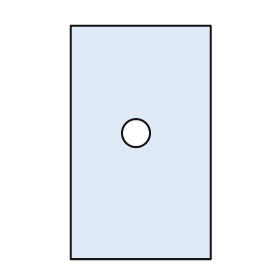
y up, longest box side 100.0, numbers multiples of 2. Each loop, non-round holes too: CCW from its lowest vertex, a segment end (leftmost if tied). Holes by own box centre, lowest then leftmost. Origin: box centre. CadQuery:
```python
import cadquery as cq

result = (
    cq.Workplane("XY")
    .moveTo(-30.0, -50.0)
    .lineTo(30.0, -50.0)
    .lineTo(30.0, 50.0)
    .lineTo(-30.0, 50.0)
    .close()
    .moveTo(-2.0, 4.0)
    .circle(6.0)
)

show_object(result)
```